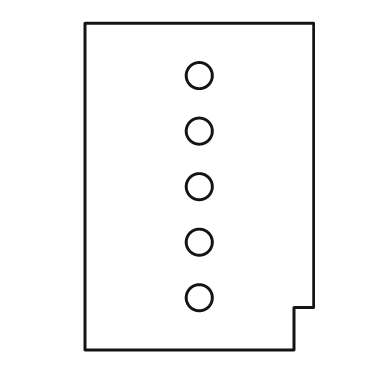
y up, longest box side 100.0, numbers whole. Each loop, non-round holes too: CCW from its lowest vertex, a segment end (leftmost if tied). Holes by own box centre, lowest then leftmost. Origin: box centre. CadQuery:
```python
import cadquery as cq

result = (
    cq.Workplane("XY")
    .moveTo(-35.0, -50.0)
    .lineTo(29.0, -50.0)
    .lineTo(29.0, -37.0)
    .lineTo(35.0, -37.0)
    .lineTo(35.0, 50.0)
    .lineTo(-35.0, 50.0)
    .close()
    .moveTo(0.0, -34.0)
    .circle(4.0)
    .moveTo(0.0, -17.0)
    .circle(4.0)
    .moveTo(0.0, 0.0)
    .circle(4.0)
    .moveTo(0.0, 17.0)
    .circle(4.0)
    .moveTo(0.0, 34.0)
    .circle(4.0)
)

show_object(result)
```